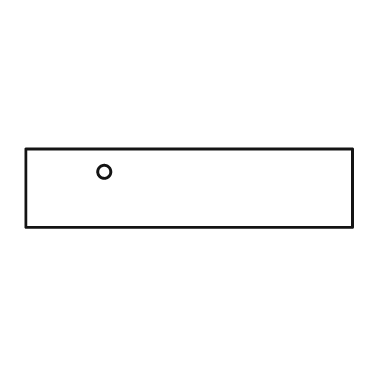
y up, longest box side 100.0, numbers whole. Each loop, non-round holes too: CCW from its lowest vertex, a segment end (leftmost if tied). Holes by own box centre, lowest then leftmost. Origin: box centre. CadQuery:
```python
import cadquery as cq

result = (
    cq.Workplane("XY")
    .moveTo(-50.0, -12.0)
    .lineTo(50.0, -12.0)
    .lineTo(50.0, 12.0)
    .lineTo(-50.0, 12.0)
    .close()
    .moveTo(-26.0, 5.0)
    .circle(2.0)
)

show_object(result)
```